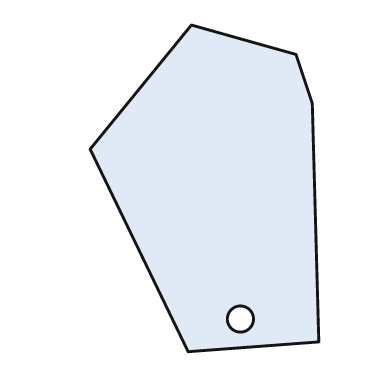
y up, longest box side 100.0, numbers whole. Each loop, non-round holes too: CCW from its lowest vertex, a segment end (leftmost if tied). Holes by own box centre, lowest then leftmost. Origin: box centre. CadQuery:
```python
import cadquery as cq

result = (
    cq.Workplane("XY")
    .moveTo(-5.0, -50.0)
    .lineTo(35.0, -47.0)
    .lineTo(33.0, 26.0)
    .lineTo(28.0, 41.0)
    .lineTo(-4.0, 50.0)
    .lineTo(-35.0, 12.0)
    .close()
    .moveTo(11.0, -40.0)
    .circle(4.0)
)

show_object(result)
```